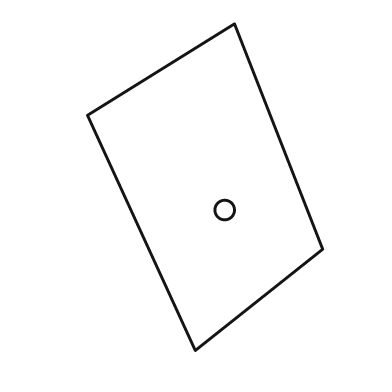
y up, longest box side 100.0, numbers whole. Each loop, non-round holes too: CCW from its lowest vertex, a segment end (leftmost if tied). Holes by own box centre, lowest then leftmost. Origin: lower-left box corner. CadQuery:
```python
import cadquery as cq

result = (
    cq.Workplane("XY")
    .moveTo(33.0, 0.0)
    .lineTo(72.0, 31.0)
    .lineTo(45.0, 100.0)
    .lineTo(0.0, 72.0)
    .close()
    .moveTo(42.0, 43.0)
    .circle(3.0)
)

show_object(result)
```